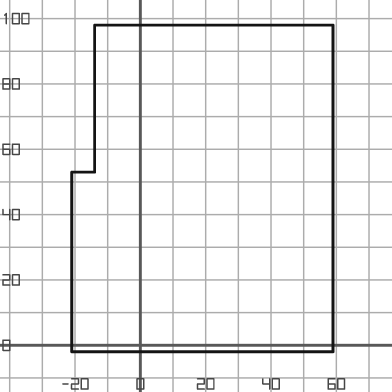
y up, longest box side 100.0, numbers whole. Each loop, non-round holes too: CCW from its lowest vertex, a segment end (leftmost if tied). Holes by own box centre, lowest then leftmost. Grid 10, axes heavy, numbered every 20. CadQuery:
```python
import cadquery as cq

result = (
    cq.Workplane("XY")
    .moveTo(-21.0, -2.0)
    .lineTo(59.0, -2.0)
    .lineTo(59.0, 98.0)
    .lineTo(-14.0, 98.0)
    .lineTo(-14.0, 53.0)
    .lineTo(-21.0, 53.0)
    .close()
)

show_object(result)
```